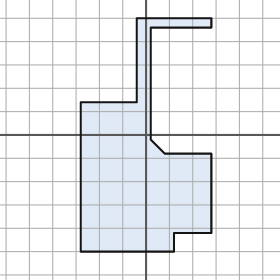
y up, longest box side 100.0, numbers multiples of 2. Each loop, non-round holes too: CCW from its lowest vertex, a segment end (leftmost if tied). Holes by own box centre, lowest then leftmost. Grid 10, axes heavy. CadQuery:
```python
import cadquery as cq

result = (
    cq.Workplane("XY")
    .moveTo(-28.0, -50.0)
    .lineTo(12.0, -50.0)
    .lineTo(12.0, -42.0)
    .lineTo(28.0, -42.0)
    .lineTo(28.0, -8.0)
    .lineTo(8.0, -8.0)
    .lineTo(2.0, -2.0)
    .lineTo(2.0, 46.0)
    .lineTo(28.0, 46.0)
    .lineTo(28.0, 50.0)
    .lineTo(-4.0, 50.0)
    .lineTo(-4.0, 14.0)
    .lineTo(-28.0, 14.0)
    .close()
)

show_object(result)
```